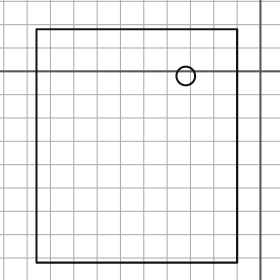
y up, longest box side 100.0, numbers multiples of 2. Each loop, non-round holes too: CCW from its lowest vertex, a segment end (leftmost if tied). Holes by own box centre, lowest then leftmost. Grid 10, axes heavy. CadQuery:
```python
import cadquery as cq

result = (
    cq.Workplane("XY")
    .moveTo(-96.0, -82.0)
    .lineTo(-10.0, -82.0)
    .lineTo(-10.0, 18.0)
    .lineTo(-96.0, 18.0)
    .close()
    .moveTo(-32.0, -2.0)
    .circle(4.0)
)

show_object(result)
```